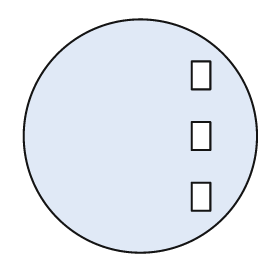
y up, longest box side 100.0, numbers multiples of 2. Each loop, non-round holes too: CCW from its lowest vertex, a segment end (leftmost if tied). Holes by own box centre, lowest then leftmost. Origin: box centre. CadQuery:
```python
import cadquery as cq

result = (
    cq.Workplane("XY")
    .moveTo(0.0, 0.0)
    .circle(50.0)
    .moveTo(22.0, -32.0)
    .lineTo(30.0, -32.0)
    .lineTo(30.0, -20.0)
    .lineTo(22.0, -20.0)
    .close()
    .moveTo(22.0, -6.0)
    .lineTo(30.0, -6.0)
    .lineTo(30.0, 6.0)
    .lineTo(22.0, 6.0)
    .close()
    .moveTo(22.0, 20.0)
    .lineTo(30.0, 20.0)
    .lineTo(30.0, 32.0)
    .lineTo(22.0, 32.0)
    .close()
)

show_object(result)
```